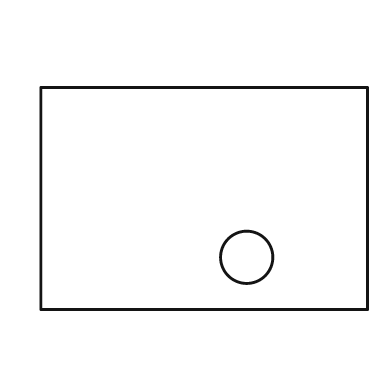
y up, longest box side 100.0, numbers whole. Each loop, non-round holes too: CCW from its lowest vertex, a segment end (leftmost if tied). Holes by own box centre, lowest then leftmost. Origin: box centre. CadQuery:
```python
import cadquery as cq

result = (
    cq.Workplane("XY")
    .moveTo(-50.0, -34.0)
    .lineTo(50.0, -34.0)
    .lineTo(50.0, 34.0)
    .lineTo(-50.0, 34.0)
    .close()
    .moveTo(13.0, -18.0)
    .circle(8.0)
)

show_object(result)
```